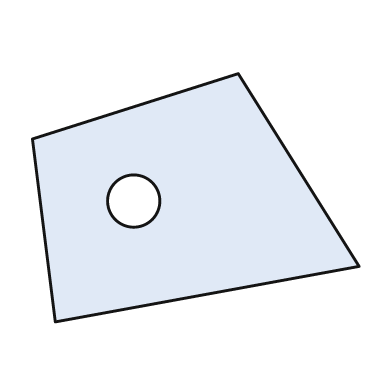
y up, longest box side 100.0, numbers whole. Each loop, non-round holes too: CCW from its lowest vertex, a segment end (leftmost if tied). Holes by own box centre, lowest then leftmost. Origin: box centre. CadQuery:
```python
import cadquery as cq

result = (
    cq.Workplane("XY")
    .moveTo(-43.0, -38.0)
    .lineTo(50.0, -21.0)
    .lineTo(13.0, 38.0)
    .lineTo(-50.0, 18.0)
    .close()
    .moveTo(-19.0, -1.0)
    .circle(8.0)
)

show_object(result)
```